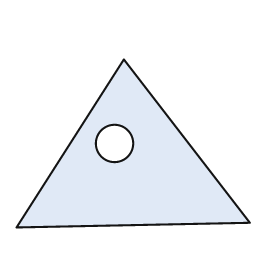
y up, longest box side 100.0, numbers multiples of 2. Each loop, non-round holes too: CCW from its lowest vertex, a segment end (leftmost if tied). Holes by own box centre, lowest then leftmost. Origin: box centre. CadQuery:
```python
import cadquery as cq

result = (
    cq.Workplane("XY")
    .moveTo(-50.0, -36.0)
    .lineTo(50.0, -34.0)
    .lineTo(-4.0, 36.0)
    .close()
    .moveTo(-8.0, 0.0)
    .circle(8.0)
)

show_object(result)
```